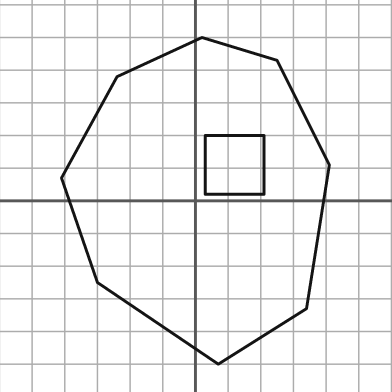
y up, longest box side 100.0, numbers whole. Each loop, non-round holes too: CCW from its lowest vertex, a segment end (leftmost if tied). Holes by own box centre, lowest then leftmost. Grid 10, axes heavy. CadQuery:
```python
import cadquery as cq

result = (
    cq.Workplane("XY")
    .moveTo(7.0, -50.0)
    .lineTo(34.0, -33.0)
    .lineTo(41.0, 11.0)
    .lineTo(25.0, 43.0)
    .lineTo(2.0, 50.0)
    .lineTo(-24.0, 38.0)
    .lineTo(-41.0, 7.0)
    .lineTo(-30.0, -25.0)
    .close()
    .moveTo(3.0, 2.0)
    .lineTo(21.0, 2.0)
    .lineTo(21.0, 20.0)
    .lineTo(3.0, 20.0)
    .close()
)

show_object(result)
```